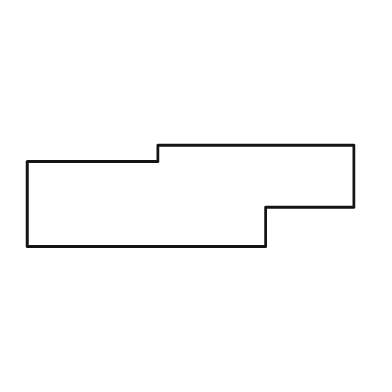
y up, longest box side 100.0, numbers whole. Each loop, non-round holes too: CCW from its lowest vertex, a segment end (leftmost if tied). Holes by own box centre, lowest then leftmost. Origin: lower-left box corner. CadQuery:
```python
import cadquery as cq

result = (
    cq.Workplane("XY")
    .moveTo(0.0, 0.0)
    .lineTo(73.0, 0.0)
    .lineTo(73.0, 12.0)
    .lineTo(100.0, 12.0)
    .lineTo(100.0, 31.0)
    .lineTo(40.0, 31.0)
    .lineTo(40.0, 26.0)
    .lineTo(0.0, 26.0)
    .close()
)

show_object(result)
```